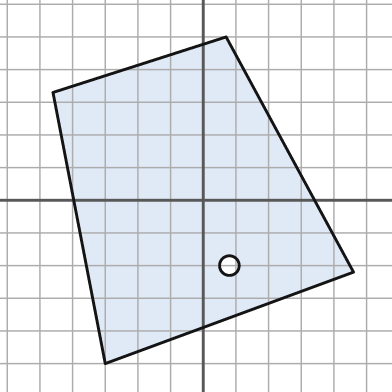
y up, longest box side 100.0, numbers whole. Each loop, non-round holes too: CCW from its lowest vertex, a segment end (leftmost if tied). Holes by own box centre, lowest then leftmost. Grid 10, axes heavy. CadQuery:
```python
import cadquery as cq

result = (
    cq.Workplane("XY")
    .moveTo(-30.0, -50.0)
    .lineTo(46.0, -22.0)
    .lineTo(7.0, 50.0)
    .lineTo(-46.0, 33.0)
    .close()
    .moveTo(8.0, -20.0)
    .circle(3.0)
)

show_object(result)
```